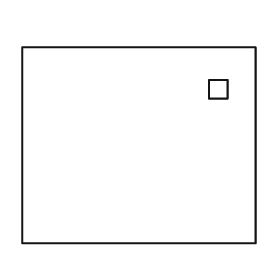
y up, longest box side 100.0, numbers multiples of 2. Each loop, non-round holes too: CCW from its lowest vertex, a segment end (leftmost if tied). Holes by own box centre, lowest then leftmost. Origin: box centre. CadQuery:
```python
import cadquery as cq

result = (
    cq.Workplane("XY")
    .moveTo(-50.0, -42.0)
    .lineTo(50.0, -42.0)
    .lineTo(50.0, 42.0)
    .lineTo(-50.0, 42.0)
    .close()
    .moveTo(30.0, 20.0)
    .lineTo(38.0, 20.0)
    .lineTo(38.0, 28.0)
    .lineTo(30.0, 28.0)
    .close()
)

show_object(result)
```